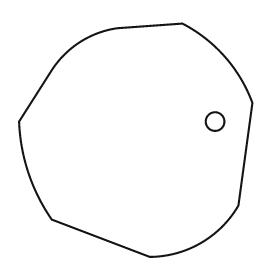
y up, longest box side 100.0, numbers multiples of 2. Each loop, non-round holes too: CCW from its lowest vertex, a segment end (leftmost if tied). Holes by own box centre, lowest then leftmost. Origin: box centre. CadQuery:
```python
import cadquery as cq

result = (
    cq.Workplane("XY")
    .moveTo(6.0, -50.0)
    .threePointArc((28.0, -44.0), (44.0, -28.0))
    .lineTo(50.0, 16.0)
    .threePointArc((38.0, 36.0), (20.0, 50.0))
    .lineTo(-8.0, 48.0)
    .threePointArc((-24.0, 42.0), (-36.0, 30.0))
    .lineTo(-50.0, 8.0)
    .threePointArc((-46.0, -14.0), (-36.0, -34.0))
    .close()
    .moveTo(34.0, 8.0)
    .circle(4.0)
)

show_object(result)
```